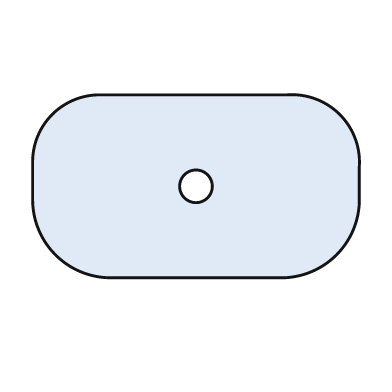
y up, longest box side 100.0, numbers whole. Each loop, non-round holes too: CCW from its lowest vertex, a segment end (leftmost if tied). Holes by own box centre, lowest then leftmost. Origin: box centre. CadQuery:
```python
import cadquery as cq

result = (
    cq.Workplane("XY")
    .moveTo(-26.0, -28.0)
    .lineTo(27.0, -28.0)
    .threePointArc((43.0, -21.0), (50.0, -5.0))
    .lineTo(50.0, 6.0)
    .threePointArc((44.0, 22.0), (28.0, 28.0))
    .lineTo(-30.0, 28.0)
    .threePointArc((-44.0, 22.0), (-50.0, 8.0))
    .lineTo(-50.0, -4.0)
    .threePointArc((-43.0, -21.0), (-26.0, -28.0))
    .close()
    .moveTo(0.0, 0.0)
    .circle(5.0)
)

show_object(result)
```